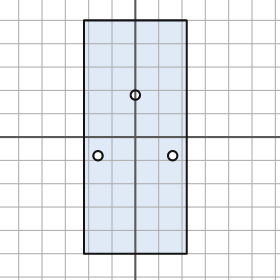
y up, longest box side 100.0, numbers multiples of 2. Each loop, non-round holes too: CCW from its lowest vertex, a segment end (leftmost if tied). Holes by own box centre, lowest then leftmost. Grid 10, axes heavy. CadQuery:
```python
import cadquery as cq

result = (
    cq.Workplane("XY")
    .moveTo(-22.0, -50.0)
    .lineTo(22.0, -50.0)
    .lineTo(22.0, 50.0)
    .lineTo(-22.0, 50.0)
    .close()
    .moveTo(-16.0, -8.0)
    .circle(2.0)
    .moveTo(16.0, -8.0)
    .circle(2.0)
    .moveTo(0.0, 18.0)
    .circle(2.0)
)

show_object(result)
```